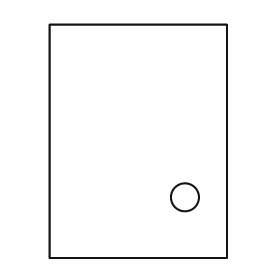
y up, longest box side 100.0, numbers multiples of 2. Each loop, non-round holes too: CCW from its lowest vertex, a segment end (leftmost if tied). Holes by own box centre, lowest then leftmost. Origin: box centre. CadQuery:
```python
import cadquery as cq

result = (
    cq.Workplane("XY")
    .moveTo(-38.0, -50.0)
    .lineTo(38.0, -50.0)
    .lineTo(38.0, 50.0)
    .lineTo(-38.0, 50.0)
    .close()
    .moveTo(20.0, -24.0)
    .circle(6.0)
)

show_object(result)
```